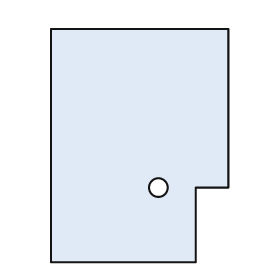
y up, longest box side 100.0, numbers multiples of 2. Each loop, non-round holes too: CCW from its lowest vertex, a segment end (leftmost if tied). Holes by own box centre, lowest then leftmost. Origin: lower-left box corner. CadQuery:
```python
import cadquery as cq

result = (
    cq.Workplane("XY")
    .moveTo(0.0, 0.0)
    .lineTo(62.0, 0.0)
    .lineTo(62.0, 32.0)
    .lineTo(76.0, 32.0)
    .lineTo(76.0, 100.0)
    .lineTo(0.0, 100.0)
    .close()
    .moveTo(46.0, 32.0)
    .circle(4.0)
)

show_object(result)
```